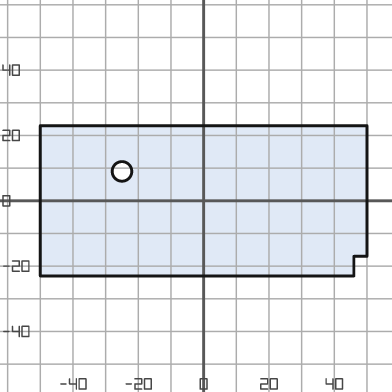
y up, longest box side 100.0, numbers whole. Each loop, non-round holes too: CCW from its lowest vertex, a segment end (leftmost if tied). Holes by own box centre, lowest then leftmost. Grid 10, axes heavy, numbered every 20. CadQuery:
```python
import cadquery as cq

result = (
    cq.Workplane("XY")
    .moveTo(-50.0, -23.0)
    .lineTo(46.0, -23.0)
    .lineTo(46.0, -17.0)
    .lineTo(50.0, -17.0)
    .lineTo(50.0, 23.0)
    .lineTo(-50.0, 23.0)
    .close()
    .moveTo(-25.0, 9.0)
    .circle(3.0)
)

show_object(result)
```